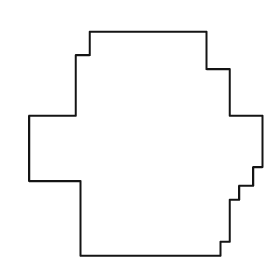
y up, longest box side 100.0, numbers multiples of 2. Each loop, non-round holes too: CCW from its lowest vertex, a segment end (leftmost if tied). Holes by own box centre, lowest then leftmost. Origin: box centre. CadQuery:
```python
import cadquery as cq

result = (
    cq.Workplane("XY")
    .moveTo(-28.0, -48.0)
    .lineTo(32.0, -48.0)
    .lineTo(32.0, -42.0)
    .lineTo(36.0, -42.0)
    .lineTo(36.0, -24.0)
    .lineTo(40.0, -24.0)
    .lineTo(40.0, -18.0)
    .lineTo(46.0, -18.0)
    .lineTo(46.0, -10.0)
    .lineTo(50.0, -10.0)
    .lineTo(50.0, 12.0)
    .lineTo(36.0, 12.0)
    .lineTo(36.0, 32.0)
    .lineTo(26.0, 32.0)
    .lineTo(26.0, 48.0)
    .lineTo(-24.0, 48.0)
    .lineTo(-24.0, 38.0)
    .lineTo(-30.0, 38.0)
    .lineTo(-30.0, 12.0)
    .lineTo(-50.0, 12.0)
    .lineTo(-50.0, -16.0)
    .lineTo(-28.0, -16.0)
    .close()
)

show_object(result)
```